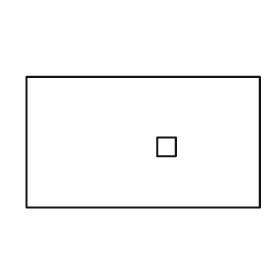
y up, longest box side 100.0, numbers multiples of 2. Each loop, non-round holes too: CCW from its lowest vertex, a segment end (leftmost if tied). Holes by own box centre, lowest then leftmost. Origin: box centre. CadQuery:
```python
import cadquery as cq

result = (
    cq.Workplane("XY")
    .moveTo(-50.0, -28.0)
    .lineTo(50.0, -28.0)
    .lineTo(50.0, 28.0)
    .lineTo(-50.0, 28.0)
    .close()
    .moveTo(6.0, -6.0)
    .lineTo(14.0, -6.0)
    .lineTo(14.0, 2.0)
    .lineTo(6.0, 2.0)
    .close()
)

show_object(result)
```